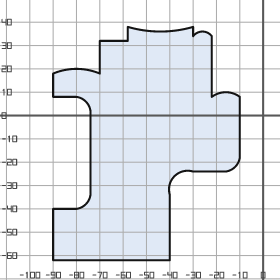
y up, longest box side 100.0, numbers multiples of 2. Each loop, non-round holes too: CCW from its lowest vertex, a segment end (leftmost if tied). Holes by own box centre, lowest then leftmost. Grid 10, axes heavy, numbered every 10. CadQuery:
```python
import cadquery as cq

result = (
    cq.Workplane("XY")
    .moveTo(-90.0, -62.0)
    .lineTo(-40.0, -62.0)
    .lineTo(-40.0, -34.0)
    .threePointArc((-38.0, -26.0), (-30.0, -24.0))
    .lineTo(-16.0, -24.0)
    .threePointArc((-12.0, -22.0), (-10.0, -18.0))
    .lineTo(-10.0, 8.0)
    .threePointArc((-16.0, 10.0), (-22.0, 8.0))
    .lineTo(-22.0, 34.0)
    .threePointArc((-26.0, 36.0), (-30.0, 34.0))
    .lineTo(-30.0, 38.0)
    .threePointArc((-44.0, 36.0), (-58.0, 38.0))
    .lineTo(-58.0, 32.0)
    .lineTo(-70.0, 32.0)
    .lineTo(-70.0, 18.0)
    .threePointArc((-80.0, 20.0), (-90.0, 18.0))
    .lineTo(-90.0, 8.0)
    .lineTo(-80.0, 8.0)
    .threePointArc((-76.0, 6.0), (-74.0, 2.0))
    .lineTo(-74.0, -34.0)
    .threePointArc((-76.0, -38.0), (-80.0, -40.0))
    .lineTo(-90.0, -40.0)
    .close()
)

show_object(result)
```